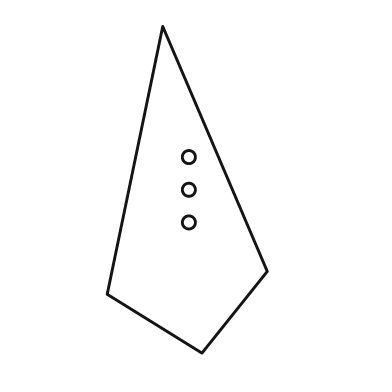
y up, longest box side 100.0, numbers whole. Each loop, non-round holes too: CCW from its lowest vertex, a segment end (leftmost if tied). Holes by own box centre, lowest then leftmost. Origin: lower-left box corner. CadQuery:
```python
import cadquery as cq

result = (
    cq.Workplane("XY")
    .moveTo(29.0, 0.0)
    .lineTo(49.0, 25.0)
    .lineTo(17.0, 100.0)
    .lineTo(0.0, 18.0)
    .close()
    .moveTo(25.0, 40.0)
    .circle(2.0)
    .moveTo(25.0, 50.0)
    .circle(2.0)
    .moveTo(25.0, 60.0)
    .circle(2.0)
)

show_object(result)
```